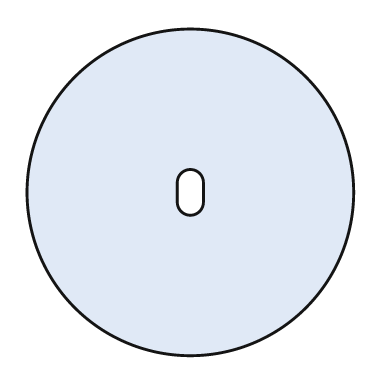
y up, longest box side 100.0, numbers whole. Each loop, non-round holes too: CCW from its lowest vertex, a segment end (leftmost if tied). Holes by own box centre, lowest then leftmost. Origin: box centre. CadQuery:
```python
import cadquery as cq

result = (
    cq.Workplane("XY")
    .moveTo(0.0, 0.0)
    .circle(50.0)
    .moveTo(-4.0, -3.0)
    .threePointArc((0.0, -7.0), (4.0, -3.0))
    .lineTo(4.0, 3.0)
    .threePointArc((0.0, 7.0), (-4.0, 3.0))
    .close()
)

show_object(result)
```